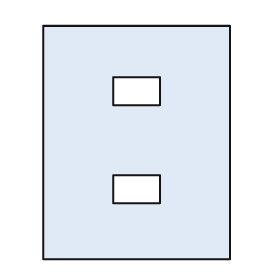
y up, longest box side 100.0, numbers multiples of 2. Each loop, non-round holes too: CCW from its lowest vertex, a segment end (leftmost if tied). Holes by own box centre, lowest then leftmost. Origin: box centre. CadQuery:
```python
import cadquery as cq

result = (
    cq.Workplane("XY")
    .moveTo(-40.0, -50.0)
    .lineTo(40.0, -50.0)
    .lineTo(40.0, 50.0)
    .lineTo(-40.0, 50.0)
    .close()
    .moveTo(-10.0, -26.0)
    .lineTo(10.0, -26.0)
    .lineTo(10.0, -14.0)
    .lineTo(-10.0, -14.0)
    .close()
    .moveTo(-10.0, 16.0)
    .lineTo(10.0, 16.0)
    .lineTo(10.0, 28.0)
    .lineTo(-10.0, 28.0)
    .close()
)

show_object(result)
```